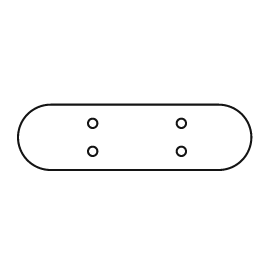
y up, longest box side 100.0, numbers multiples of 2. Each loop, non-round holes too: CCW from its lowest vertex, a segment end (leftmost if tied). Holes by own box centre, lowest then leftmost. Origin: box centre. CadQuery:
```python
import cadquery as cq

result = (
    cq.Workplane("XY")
    .moveTo(-36.0, -14.0)
    .lineTo(36.0, -14.0)
    .threePointArc((50.0, 0.0), (36.0, 14.0))
    .lineTo(-36.0, 14.0)
    .threePointArc((-50.0, 0.0), (-36.0, -14.0))
    .close()
    .moveTo(-18.0, -6.0)
    .circle(2.0)
    .moveTo(20.0, -6.0)
    .circle(2.0)
    .moveTo(-18.0, 6.0)
    .circle(2.0)
    .moveTo(20.0, 6.0)
    .circle(2.0)
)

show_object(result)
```